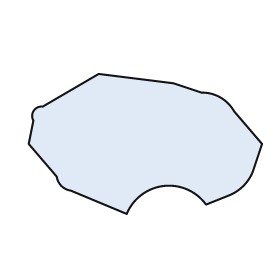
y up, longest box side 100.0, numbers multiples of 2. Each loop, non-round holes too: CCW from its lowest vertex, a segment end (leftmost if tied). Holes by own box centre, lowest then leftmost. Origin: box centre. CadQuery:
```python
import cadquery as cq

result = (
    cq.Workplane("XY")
    .moveTo(-8.0, -30.0)
    .threePointArc((8.0, -18.0), (26.0, -26.0))
    .lineTo(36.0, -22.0)
    .threePointArc((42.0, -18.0), (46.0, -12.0))
    .lineTo(50.0, 0.0)
    .lineTo(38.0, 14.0)
    .threePointArc((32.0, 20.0), (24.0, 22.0))
    .lineTo(12.0, 26.0)
    .lineTo(-20.0, 30.0)
    .lineTo(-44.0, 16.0)
    .threePointArc((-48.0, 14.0), (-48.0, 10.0))
    .lineTo(-50.0, 0.0)
    .lineTo(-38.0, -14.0)
    .threePointArc((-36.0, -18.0), (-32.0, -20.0))
    .close()
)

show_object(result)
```